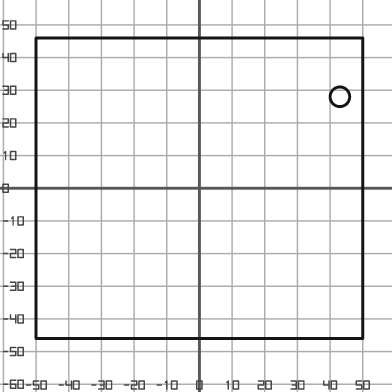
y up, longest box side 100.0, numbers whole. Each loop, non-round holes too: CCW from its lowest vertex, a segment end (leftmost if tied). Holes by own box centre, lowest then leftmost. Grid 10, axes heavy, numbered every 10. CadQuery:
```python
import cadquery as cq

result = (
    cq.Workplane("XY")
    .moveTo(-50.0, -46.0)
    .lineTo(50.0, -46.0)
    .lineTo(50.0, 46.0)
    .lineTo(-50.0, 46.0)
    .close()
    .moveTo(43.0, 28.0)
    .circle(3.0)
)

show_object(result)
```